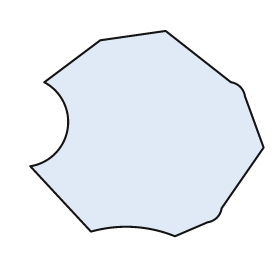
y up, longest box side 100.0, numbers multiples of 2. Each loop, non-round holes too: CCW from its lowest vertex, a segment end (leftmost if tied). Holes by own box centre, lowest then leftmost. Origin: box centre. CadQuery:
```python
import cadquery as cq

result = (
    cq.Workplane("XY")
    .moveTo(12.0, -44.0)
    .lineTo(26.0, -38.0)
    .threePointArc((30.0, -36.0), (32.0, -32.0))
    .lineTo(50.0, -6.0)
    .lineTo(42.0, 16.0)
    .threePointArc((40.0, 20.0), (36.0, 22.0))
    .lineTo(8.0, 44.0)
    .lineTo(-20.0, 40.0)
    .lineTo(-44.0, 22.0)
    .threePointArc((-34.0, 2.0), (-50.0, -14.0))
    .lineTo(-24.0, -42.0)
    .threePointArc((-6.0, -40.0), (12.0, -44.0))
    .close()
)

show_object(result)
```